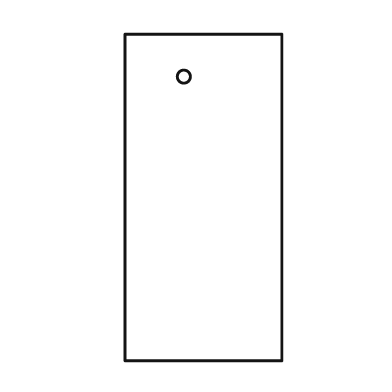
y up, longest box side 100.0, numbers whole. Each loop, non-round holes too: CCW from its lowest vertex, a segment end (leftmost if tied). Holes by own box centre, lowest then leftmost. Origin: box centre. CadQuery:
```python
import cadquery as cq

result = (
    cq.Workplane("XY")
    .moveTo(-24.0, -50.0)
    .lineTo(24.0, -50.0)
    .lineTo(24.0, 50.0)
    .lineTo(-24.0, 50.0)
    .close()
    .moveTo(-6.0, 37.0)
    .circle(2.0)
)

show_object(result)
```